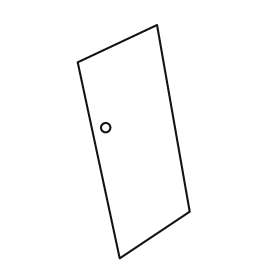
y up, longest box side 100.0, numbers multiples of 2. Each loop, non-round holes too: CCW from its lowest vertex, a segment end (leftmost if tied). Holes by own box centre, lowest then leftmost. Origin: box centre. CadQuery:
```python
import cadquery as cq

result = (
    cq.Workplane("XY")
    .moveTo(-6.0, -50.0)
    .lineTo(24.0, -30.0)
    .lineTo(10.0, 50.0)
    .lineTo(-24.0, 34.0)
    .close()
    .moveTo(-12.0, 6.0)
    .circle(2.0)
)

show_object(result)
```